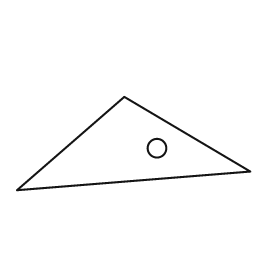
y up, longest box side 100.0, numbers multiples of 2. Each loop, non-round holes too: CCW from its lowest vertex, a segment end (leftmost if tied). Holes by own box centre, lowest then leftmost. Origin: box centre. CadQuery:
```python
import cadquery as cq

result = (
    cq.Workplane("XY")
    .moveTo(-50.0, -20.0)
    .lineTo(50.0, -12.0)
    .lineTo(-4.0, 20.0)
    .close()
    .moveTo(10.0, -2.0)
    .circle(4.0)
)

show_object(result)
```